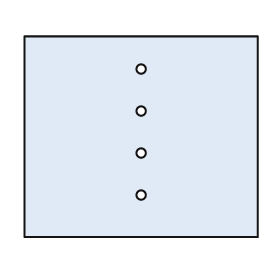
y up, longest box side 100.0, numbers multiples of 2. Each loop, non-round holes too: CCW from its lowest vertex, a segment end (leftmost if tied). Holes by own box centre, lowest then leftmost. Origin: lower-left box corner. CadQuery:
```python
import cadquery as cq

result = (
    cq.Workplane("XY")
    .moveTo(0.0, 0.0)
    .lineTo(100.0, 0.0)
    .lineTo(100.0, 86.0)
    .lineTo(0.0, 86.0)
    .close()
    .moveTo(50.0, 18.0)
    .circle(2.0)
    .moveTo(50.0, 36.0)
    .circle(2.0)
    .moveTo(50.0, 54.0)
    .circle(2.0)
    .moveTo(50.0, 72.0)
    .circle(2.0)
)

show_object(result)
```